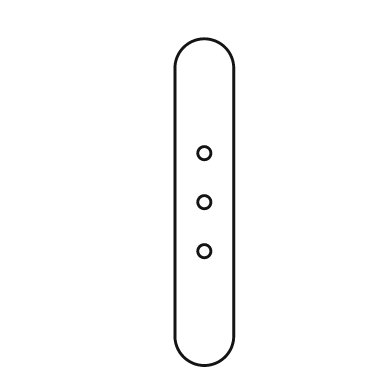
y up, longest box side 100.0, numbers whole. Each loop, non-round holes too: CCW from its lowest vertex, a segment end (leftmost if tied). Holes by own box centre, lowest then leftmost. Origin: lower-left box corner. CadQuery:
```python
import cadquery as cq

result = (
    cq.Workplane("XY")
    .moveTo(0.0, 9.0)
    .threePointArc((9.0, 0.0), (18.0, 9.0))
    .lineTo(18.0, 91.0)
    .threePointArc((9.0, 100.0), (0.0, 91.0))
    .close()
    .moveTo(9.0, 35.0)
    .circle(2.0)
    .moveTo(9.0, 50.0)
    .circle(2.0)
    .moveTo(9.0, 65.0)
    .circle(2.0)
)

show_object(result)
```